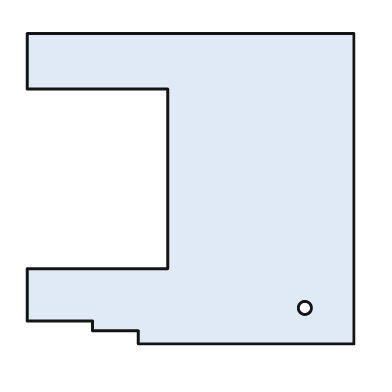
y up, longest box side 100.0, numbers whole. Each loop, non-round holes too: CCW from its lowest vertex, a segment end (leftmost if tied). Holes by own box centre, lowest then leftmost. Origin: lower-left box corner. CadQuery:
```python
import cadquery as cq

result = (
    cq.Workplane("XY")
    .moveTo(34.0, 0.0)
    .lineTo(100.0, 0.0)
    .lineTo(100.0, 95.0)
    .lineTo(0.0, 95.0)
    .lineTo(0.0, 78.0)
    .lineTo(43.0, 78.0)
    .lineTo(43.0, 23.0)
    .lineTo(0.0, 23.0)
    .lineTo(0.0, 7.0)
    .lineTo(20.0, 7.0)
    .lineTo(20.0, 4.0)
    .lineTo(34.0, 4.0)
    .close()
    .moveTo(85.0, 11.0)
    .circle(2.0)
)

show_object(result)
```